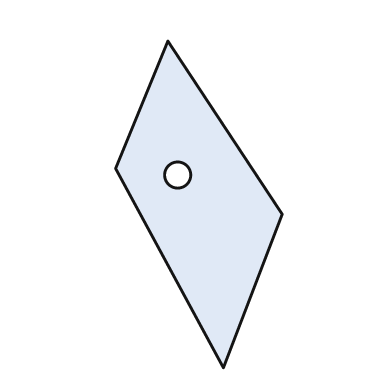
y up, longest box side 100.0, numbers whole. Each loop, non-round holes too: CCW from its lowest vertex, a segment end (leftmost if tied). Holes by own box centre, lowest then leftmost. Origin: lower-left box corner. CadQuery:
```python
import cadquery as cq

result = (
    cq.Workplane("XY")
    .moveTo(33.0, 0.0)
    .lineTo(51.0, 47.0)
    .lineTo(16.0, 100.0)
    .lineTo(0.0, 61.0)
    .close()
    .moveTo(19.0, 59.0)
    .circle(4.0)
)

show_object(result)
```